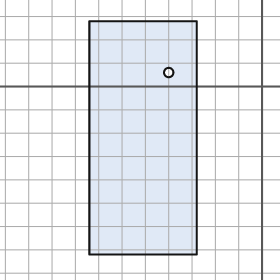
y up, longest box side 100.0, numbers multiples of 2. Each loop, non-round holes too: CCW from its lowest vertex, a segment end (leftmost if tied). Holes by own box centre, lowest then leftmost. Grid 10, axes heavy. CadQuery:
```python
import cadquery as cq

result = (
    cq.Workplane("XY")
    .moveTo(-74.0, -72.0)
    .lineTo(-28.0, -72.0)
    .lineTo(-28.0, 28.0)
    .lineTo(-74.0, 28.0)
    .close()
    .moveTo(-40.0, 6.0)
    .circle(2.0)
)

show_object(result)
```